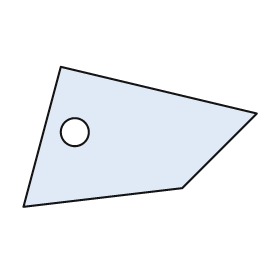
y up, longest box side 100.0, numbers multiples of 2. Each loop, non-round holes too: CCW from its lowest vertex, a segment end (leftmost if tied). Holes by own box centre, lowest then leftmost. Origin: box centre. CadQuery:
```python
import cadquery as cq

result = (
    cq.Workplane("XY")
    .moveTo(-50.0, -30.0)
    .lineTo(18.0, -22.0)
    .lineTo(50.0, 10.0)
    .lineTo(-34.0, 30.0)
    .close()
    .moveTo(-28.0, 2.0)
    .circle(6.0)
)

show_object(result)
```